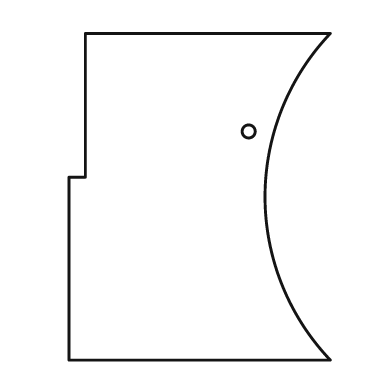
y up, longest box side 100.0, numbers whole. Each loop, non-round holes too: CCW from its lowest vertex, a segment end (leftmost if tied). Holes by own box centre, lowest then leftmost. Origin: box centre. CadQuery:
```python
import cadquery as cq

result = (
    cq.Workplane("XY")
    .moveTo(-40.0, -50.0)
    .lineTo(40.0, -50.0)
    .threePointArc((20.0, 0.0), (40.0, 50.0))
    .lineTo(-35.0, 50.0)
    .lineTo(-35.0, 6.0)
    .lineTo(-40.0, 6.0)
    .close()
    .moveTo(15.0, 20.0)
    .circle(2.0)
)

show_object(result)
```